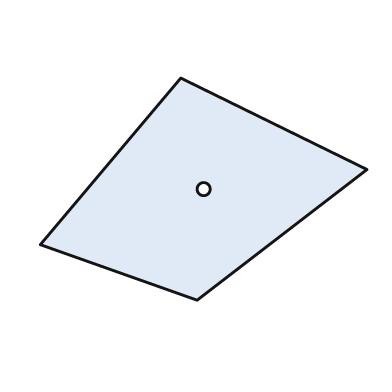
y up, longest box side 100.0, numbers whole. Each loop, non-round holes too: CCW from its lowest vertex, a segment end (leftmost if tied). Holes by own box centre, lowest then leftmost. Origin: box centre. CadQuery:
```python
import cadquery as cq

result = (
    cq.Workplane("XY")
    .moveTo(-2.0, -34.0)
    .lineTo(50.0, 6.0)
    .lineTo(-7.0, 34.0)
    .lineTo(-50.0, -17.0)
    .close()
    .moveTo(0.0, 0.0)
    .circle(2.0)
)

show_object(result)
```